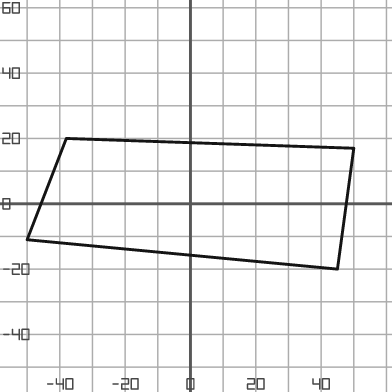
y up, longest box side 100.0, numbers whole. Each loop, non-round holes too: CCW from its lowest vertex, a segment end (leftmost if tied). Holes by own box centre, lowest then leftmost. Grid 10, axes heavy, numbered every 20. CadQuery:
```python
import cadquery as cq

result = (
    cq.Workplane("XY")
    .moveTo(45.0, -20.0)
    .lineTo(50.0, 17.0)
    .lineTo(-38.0, 20.0)
    .lineTo(-50.0, -11.0)
    .close()
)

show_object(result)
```